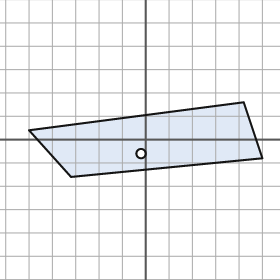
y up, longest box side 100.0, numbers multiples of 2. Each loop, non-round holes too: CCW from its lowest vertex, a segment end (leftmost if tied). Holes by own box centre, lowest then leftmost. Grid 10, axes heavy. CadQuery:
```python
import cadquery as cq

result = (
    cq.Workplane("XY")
    .moveTo(-32.0, -16.0)
    .lineTo(50.0, -8.0)
    .lineTo(42.0, 16.0)
    .lineTo(-50.0, 4.0)
    .close()
    .moveTo(-2.0, -6.0)
    .circle(2.0)
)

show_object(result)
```